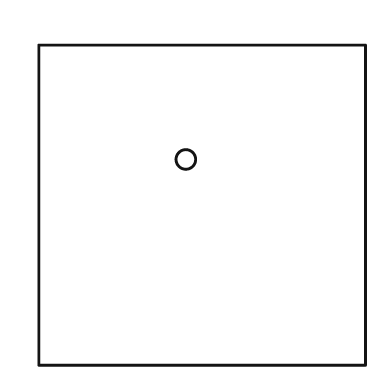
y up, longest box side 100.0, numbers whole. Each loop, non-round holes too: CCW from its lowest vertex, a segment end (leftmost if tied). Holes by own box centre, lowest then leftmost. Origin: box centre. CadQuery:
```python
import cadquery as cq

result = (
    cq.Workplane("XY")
    .moveTo(-50.0, -49.0)
    .lineTo(50.0, -49.0)
    .lineTo(50.0, 49.0)
    .lineTo(-50.0, 49.0)
    .close()
    .moveTo(-5.0, 14.0)
    .circle(3.0)
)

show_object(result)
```